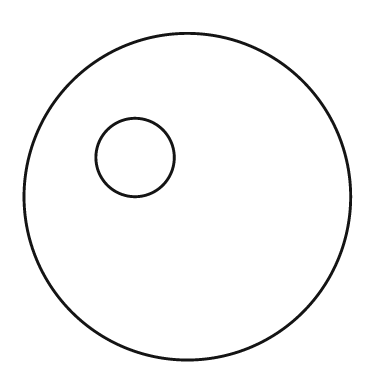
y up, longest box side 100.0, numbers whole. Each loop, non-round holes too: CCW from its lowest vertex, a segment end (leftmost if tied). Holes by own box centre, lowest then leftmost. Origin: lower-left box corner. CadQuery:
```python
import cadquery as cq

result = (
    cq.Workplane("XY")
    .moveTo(50.0, 50.0)
    .circle(50.0)
    .moveTo(34.0, 62.0)
    .circle(12.0)
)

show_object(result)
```